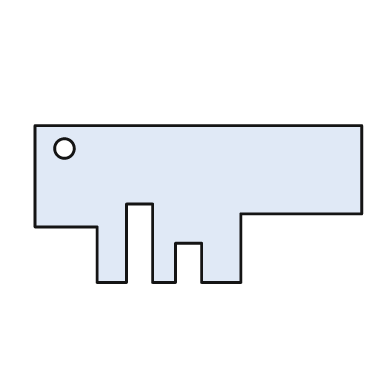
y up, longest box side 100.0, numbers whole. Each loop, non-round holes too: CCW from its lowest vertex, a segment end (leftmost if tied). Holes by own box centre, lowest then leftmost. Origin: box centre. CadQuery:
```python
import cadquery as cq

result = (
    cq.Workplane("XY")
    .moveTo(-31.0, -24.0)
    .lineTo(-22.0, -24.0)
    .lineTo(-22.0, 0.0)
    .lineTo(-14.0, 0.0)
    .lineTo(-14.0, -24.0)
    .lineTo(-7.0, -24.0)
    .lineTo(-7.0, -12.0)
    .lineTo(1.0, -12.0)
    .lineTo(1.0, -24.0)
    .lineTo(13.0, -24.0)
    .lineTo(13.0, -3.0)
    .lineTo(50.0, -3.0)
    .lineTo(50.0, 24.0)
    .lineTo(-50.0, 24.0)
    .lineTo(-50.0, -7.0)
    .lineTo(-31.0, -7.0)
    .close()
    .moveTo(-41.0, 17.0)
    .circle(3.0)
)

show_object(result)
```